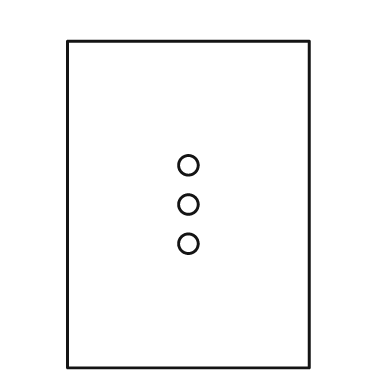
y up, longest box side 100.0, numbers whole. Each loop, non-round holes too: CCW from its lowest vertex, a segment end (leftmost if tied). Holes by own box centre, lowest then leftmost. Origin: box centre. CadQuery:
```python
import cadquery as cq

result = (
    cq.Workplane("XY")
    .moveTo(-37.0, -50.0)
    .lineTo(37.0, -50.0)
    .lineTo(37.0, 50.0)
    .lineTo(-37.0, 50.0)
    .close()
    .moveTo(0.0, -12.0)
    .circle(3.0)
    .moveTo(0.0, 0.0)
    .circle(3.0)
    .moveTo(0.0, 12.0)
    .circle(3.0)
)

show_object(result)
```